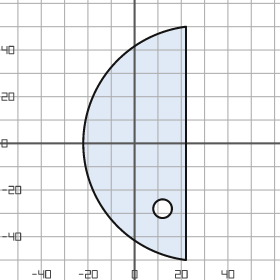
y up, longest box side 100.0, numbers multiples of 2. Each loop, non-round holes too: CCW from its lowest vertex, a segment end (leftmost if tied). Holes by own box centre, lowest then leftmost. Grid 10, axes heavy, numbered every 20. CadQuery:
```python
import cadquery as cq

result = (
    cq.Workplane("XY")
    .moveTo(22.0, -50.0)
    .lineTo(22.0, 50.0)
    .threePointArc((-22.0, 0.0), (22.0, -50.0))
    .close()
    .moveTo(12.0, -28.0)
    .circle(4.0)
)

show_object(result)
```